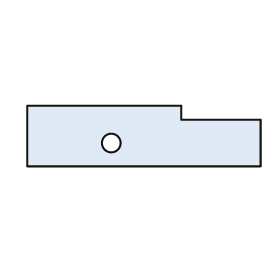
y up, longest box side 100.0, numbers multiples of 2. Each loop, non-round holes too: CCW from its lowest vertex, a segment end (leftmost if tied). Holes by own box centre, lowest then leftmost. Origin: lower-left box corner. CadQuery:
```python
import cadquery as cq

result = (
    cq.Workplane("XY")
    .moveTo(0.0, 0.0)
    .lineTo(100.0, 0.0)
    .lineTo(100.0, 20.0)
    .lineTo(66.0, 20.0)
    .lineTo(66.0, 26.0)
    .lineTo(0.0, 26.0)
    .close()
    .moveTo(36.0, 10.0)
    .circle(4.0)
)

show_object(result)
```